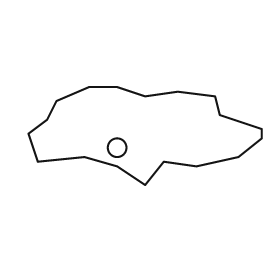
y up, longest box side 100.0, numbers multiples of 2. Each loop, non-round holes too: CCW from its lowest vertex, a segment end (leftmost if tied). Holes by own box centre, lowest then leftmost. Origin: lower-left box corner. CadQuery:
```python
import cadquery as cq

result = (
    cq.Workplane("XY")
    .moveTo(50.0, 0.0)
    .lineTo(58.0, 10.0)
    .lineTo(72.0, 8.0)
    .lineTo(90.0, 12.0)
    .lineTo(100.0, 20.0)
    .lineTo(100.0, 24.0)
    .lineTo(82.0, 30.0)
    .lineTo(80.0, 38.0)
    .lineTo(64.0, 40.0)
    .lineTo(50.0, 38.0)
    .lineTo(38.0, 42.0)
    .lineTo(26.0, 42.0)
    .lineTo(12.0, 36.0)
    .lineTo(8.0, 28.0)
    .lineTo(0.0, 22.0)
    .lineTo(4.0, 10.0)
    .lineTo(24.0, 12.0)
    .lineTo(38.0, 8.0)
    .close()
    .moveTo(38.0, 16.0)
    .circle(4.0)
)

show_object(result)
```